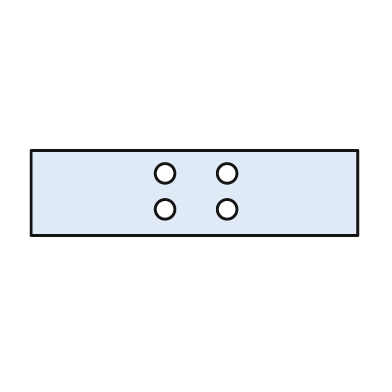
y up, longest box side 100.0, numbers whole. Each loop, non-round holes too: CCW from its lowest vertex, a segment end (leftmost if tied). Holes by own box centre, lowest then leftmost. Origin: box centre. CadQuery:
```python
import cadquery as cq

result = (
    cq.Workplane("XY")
    .moveTo(-50.0, -13.0)
    .lineTo(50.0, -13.0)
    .lineTo(50.0, 13.0)
    .lineTo(-50.0, 13.0)
    .close()
    .moveTo(-9.0, -5.0)
    .circle(3.0)
    .moveTo(10.0, -5.0)
    .circle(3.0)
    .moveTo(-9.0, 6.0)
    .circle(3.0)
    .moveTo(10.0, 6.0)
    .circle(3.0)
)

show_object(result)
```